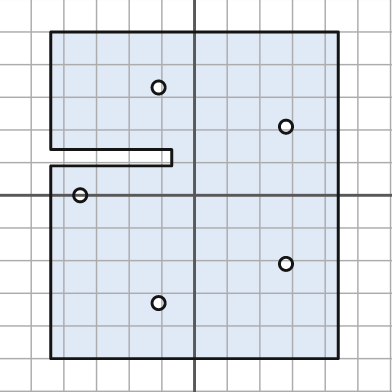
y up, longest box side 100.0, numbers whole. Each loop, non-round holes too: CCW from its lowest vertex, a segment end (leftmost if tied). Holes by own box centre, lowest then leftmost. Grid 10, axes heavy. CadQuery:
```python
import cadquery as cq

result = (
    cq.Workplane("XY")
    .moveTo(-44.0, -50.0)
    .lineTo(44.0, -50.0)
    .lineTo(44.0, 50.0)
    .lineTo(-44.0, 50.0)
    .lineTo(-44.0, 14.0)
    .lineTo(-7.0, 14.0)
    .lineTo(-7.0, 9.0)
    .lineTo(-44.0, 9.0)
    .close()
    .moveTo(-11.0, -33.0)
    .circle(2.0)
    .moveTo(28.0, -21.0)
    .circle(2.0)
    .moveTo(-35.0, 0.0)
    .circle(2.0)
    .moveTo(28.0, 21.0)
    .circle(2.0)
    .moveTo(-11.0, 33.0)
    .circle(2.0)
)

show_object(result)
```